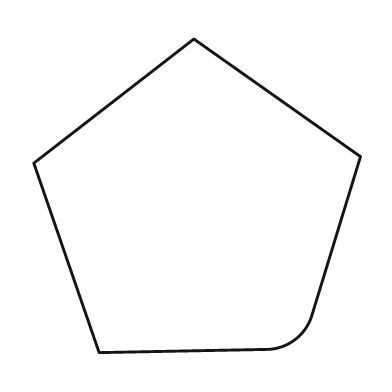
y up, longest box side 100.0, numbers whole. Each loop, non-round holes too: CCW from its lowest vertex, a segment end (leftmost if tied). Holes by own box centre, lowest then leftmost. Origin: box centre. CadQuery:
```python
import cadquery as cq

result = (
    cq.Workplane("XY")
    .moveTo(-30.0, -48.0)
    .lineTo(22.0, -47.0)
    .threePointArc((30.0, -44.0), (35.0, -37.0))
    .lineTo(50.0, 12.0)
    .lineTo(-1.0, 48.0)
    .lineTo(-50.0, 10.0)
    .close()
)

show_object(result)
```